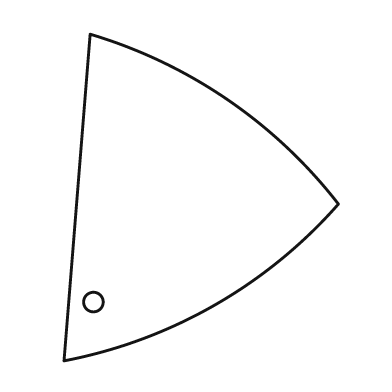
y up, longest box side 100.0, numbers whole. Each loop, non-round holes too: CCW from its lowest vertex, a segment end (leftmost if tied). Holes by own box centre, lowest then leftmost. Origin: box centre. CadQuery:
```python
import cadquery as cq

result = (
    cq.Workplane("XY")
    .moveTo(-42.0, -50.0)
    .threePointArc((4.0, -33.0), (42.0, -2.0))
    .threePointArc((8.0, 30.0), (-34.0, 50.0))
    .close()
    .moveTo(-33.0, -32.0)
    .circle(3.0)
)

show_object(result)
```